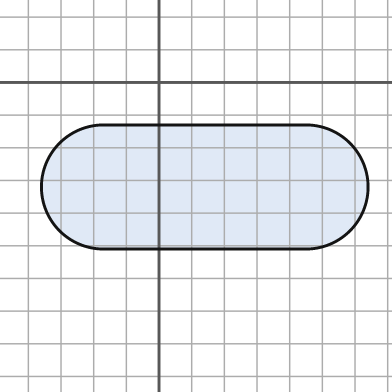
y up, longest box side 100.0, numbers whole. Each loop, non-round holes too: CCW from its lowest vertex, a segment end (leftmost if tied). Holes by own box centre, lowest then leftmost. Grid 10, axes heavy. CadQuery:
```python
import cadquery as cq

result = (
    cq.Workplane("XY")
    .moveTo(-17.0, -51.0)
    .lineTo(45.0, -51.0)
    .threePointArc((64.0, -32.0), (45.0, -13.0))
    .lineTo(-17.0, -13.0)
    .threePointArc((-36.0, -32.0), (-17.0, -51.0))
    .close()
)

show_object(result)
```